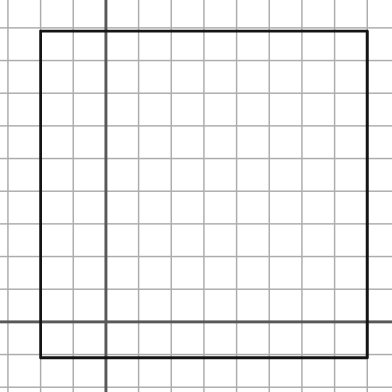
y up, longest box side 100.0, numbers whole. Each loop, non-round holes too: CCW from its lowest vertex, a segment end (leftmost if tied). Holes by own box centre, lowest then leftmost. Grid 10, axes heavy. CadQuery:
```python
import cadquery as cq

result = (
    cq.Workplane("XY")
    .moveTo(-20.0, -11.0)
    .lineTo(80.0, -11.0)
    .lineTo(80.0, 89.0)
    .lineTo(-20.0, 89.0)
    .close()
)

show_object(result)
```